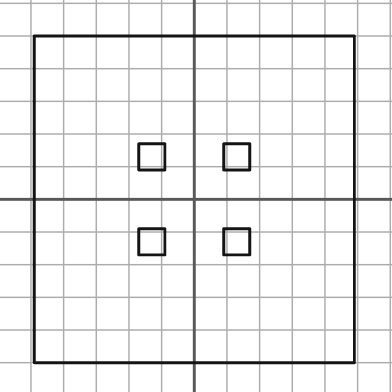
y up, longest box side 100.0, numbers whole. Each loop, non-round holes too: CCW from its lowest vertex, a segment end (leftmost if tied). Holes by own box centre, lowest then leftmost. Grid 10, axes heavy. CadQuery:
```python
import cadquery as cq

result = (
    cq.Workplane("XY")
    .moveTo(-49.0, -50.0)
    .lineTo(49.0, -50.0)
    .lineTo(49.0, 50.0)
    .lineTo(-49.0, 50.0)
    .close()
    .moveTo(-17.0, -17.0)
    .lineTo(-9.0, -17.0)
    .lineTo(-9.0, -9.0)
    .lineTo(-17.0, -9.0)
    .close()
    .moveTo(9.0, -17.0)
    .lineTo(17.0, -17.0)
    .lineTo(17.0, -9.0)
    .lineTo(9.0, -9.0)
    .close()
    .moveTo(-17.0, 9.0)
    .lineTo(-9.0, 9.0)
    .lineTo(-9.0, 17.0)
    .lineTo(-17.0, 17.0)
    .close()
    .moveTo(9.0, 9.0)
    .lineTo(17.0, 9.0)
    .lineTo(17.0, 17.0)
    .lineTo(9.0, 17.0)
    .close()
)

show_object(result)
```